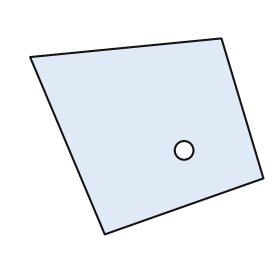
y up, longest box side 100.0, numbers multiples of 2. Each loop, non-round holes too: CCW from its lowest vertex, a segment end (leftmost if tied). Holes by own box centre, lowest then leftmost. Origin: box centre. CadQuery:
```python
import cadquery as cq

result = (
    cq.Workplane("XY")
    .moveTo(-18.0, -42.0)
    .lineTo(50.0, -18.0)
    .lineTo(32.0, 42.0)
    .lineTo(-50.0, 34.0)
    .close()
    .moveTo(16.0, -6.0)
    .circle(4.0)
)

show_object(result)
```